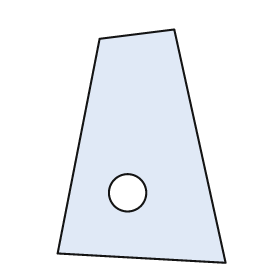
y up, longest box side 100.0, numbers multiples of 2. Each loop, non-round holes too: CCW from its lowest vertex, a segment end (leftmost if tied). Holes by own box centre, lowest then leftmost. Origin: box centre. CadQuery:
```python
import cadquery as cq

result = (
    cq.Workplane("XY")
    .moveTo(36.0, -50.0)
    .lineTo(14.0, 50.0)
    .lineTo(-18.0, 46.0)
    .lineTo(-36.0, -46.0)
    .close()
    .moveTo(-6.0, -20.0)
    .circle(8.0)
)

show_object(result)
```